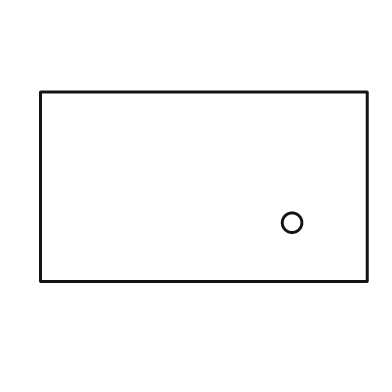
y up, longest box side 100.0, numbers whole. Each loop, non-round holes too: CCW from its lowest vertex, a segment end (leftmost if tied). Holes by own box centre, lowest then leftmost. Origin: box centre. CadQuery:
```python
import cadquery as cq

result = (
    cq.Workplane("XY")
    .moveTo(-50.0, -29.0)
    .lineTo(50.0, -29.0)
    .lineTo(50.0, 29.0)
    .lineTo(-50.0, 29.0)
    .close()
    .moveTo(27.0, -11.0)
    .circle(3.0)
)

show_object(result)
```